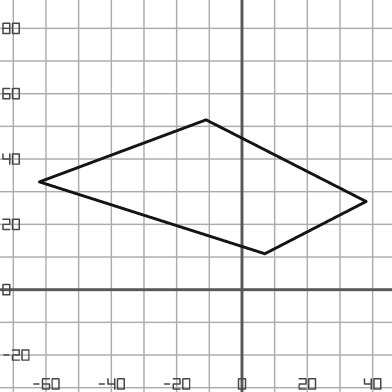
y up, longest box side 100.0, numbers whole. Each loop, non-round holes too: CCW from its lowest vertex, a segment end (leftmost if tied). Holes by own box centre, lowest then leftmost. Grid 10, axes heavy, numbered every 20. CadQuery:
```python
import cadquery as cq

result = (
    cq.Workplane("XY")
    .moveTo(7.0, 11.0)
    .lineTo(38.0, 27.0)
    .lineTo(-11.0, 52.0)
    .lineTo(-62.0, 33.0)
    .close()
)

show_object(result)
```